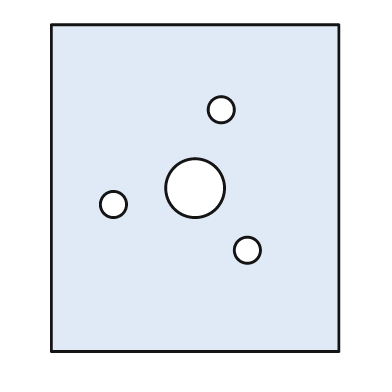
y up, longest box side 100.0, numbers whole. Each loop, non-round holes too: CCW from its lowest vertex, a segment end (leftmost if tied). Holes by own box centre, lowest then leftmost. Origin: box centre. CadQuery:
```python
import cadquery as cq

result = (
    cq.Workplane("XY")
    .moveTo(-44.0, -50.0)
    .lineTo(44.0, -50.0)
    .lineTo(44.0, 50.0)
    .lineTo(-44.0, 50.0)
    .close()
    .moveTo(16.0, -19.0)
    .circle(4.0)
    .moveTo(-25.0, -5.0)
    .circle(4.0)
    .moveTo(0.0, 0.0)
    .circle(9.0)
    .moveTo(8.0, 24.0)
    .circle(4.0)
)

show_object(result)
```